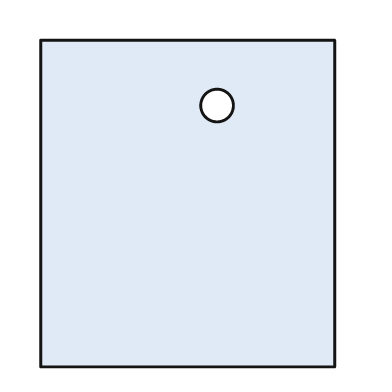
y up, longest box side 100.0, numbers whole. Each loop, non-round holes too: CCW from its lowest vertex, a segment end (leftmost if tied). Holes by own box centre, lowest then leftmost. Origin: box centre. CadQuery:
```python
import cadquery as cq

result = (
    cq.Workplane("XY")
    .moveTo(-45.0, -50.0)
    .lineTo(45.0, -50.0)
    .lineTo(45.0, 50.0)
    .lineTo(-45.0, 50.0)
    .close()
    .moveTo(9.0, 30.0)
    .circle(5.0)
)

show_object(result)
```